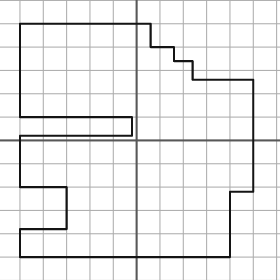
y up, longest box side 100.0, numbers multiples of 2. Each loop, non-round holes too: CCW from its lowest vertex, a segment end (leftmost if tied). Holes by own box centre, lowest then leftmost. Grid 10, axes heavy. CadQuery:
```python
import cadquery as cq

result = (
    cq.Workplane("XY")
    .moveTo(-50.0, -50.0)
    .lineTo(40.0, -50.0)
    .lineTo(40.0, -22.0)
    .lineTo(50.0, -22.0)
    .lineTo(50.0, 26.0)
    .lineTo(24.0, 26.0)
    .lineTo(24.0, 34.0)
    .lineTo(16.0, 34.0)
    .lineTo(16.0, 40.0)
    .lineTo(6.0, 40.0)
    .lineTo(6.0, 50.0)
    .lineTo(-50.0, 50.0)
    .lineTo(-50.0, 10.0)
    .lineTo(-2.0, 10.0)
    .lineTo(-2.0, 2.0)
    .lineTo(-50.0, 2.0)
    .lineTo(-50.0, -20.0)
    .lineTo(-30.0, -20.0)
    .lineTo(-30.0, -38.0)
    .lineTo(-50.0, -38.0)
    .close()
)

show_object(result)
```